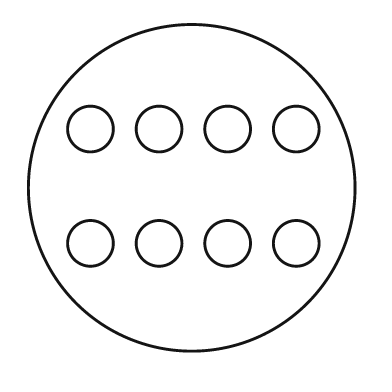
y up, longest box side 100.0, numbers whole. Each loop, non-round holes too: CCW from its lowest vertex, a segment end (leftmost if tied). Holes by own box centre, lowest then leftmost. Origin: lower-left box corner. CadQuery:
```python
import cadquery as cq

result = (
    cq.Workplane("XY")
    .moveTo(50.0, 50.0)
    .circle(50.0)
    .moveTo(19.0, 33.0)
    .circle(7.0)
    .moveTo(40.0, 33.0)
    .circle(7.0)
    .moveTo(61.0, 33.0)
    .circle(7.0)
    .moveTo(82.0, 33.0)
    .circle(7.0)
    .moveTo(19.0, 68.0)
    .circle(7.0)
    .moveTo(40.0, 68.0)
    .circle(7.0)
    .moveTo(61.0, 68.0)
    .circle(7.0)
    .moveTo(82.0, 68.0)
    .circle(7.0)
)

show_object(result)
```